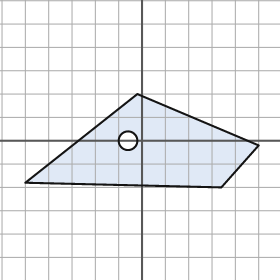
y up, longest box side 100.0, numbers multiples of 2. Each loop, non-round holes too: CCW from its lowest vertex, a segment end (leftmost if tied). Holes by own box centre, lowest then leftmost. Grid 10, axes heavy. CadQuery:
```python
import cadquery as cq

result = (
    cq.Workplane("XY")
    .moveTo(34.0, -20.0)
    .lineTo(50.0, -2.0)
    .lineTo(-2.0, 20.0)
    .lineTo(-50.0, -18.0)
    .close()
    .moveTo(-6.0, 0.0)
    .circle(4.0)
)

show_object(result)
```